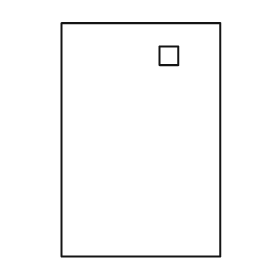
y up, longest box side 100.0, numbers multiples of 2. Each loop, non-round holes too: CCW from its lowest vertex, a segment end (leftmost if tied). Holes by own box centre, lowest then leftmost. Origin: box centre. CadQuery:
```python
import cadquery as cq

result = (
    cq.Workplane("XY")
    .moveTo(-34.0, -50.0)
    .lineTo(34.0, -50.0)
    .lineTo(34.0, 50.0)
    .lineTo(-34.0, 50.0)
    .close()
    .moveTo(8.0, 32.0)
    .lineTo(16.0, 32.0)
    .lineTo(16.0, 40.0)
    .lineTo(8.0, 40.0)
    .close()
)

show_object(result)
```